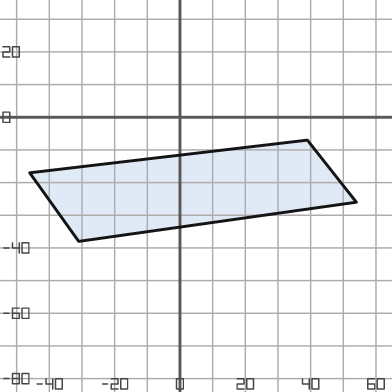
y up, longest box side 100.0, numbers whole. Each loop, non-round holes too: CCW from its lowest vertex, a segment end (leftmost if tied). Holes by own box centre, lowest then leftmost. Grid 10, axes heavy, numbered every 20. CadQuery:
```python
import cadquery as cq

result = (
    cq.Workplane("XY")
    .moveTo(-31.0, -38.0)
    .lineTo(54.0, -26.0)
    .lineTo(39.0, -7.0)
    .lineTo(-46.0, -17.0)
    .close()
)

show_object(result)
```